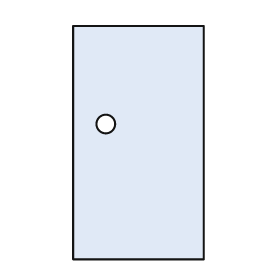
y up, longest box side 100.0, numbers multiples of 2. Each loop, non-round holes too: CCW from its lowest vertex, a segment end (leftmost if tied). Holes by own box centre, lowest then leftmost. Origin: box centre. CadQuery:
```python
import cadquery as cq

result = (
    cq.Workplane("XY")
    .moveTo(-28.0, -50.0)
    .lineTo(28.0, -50.0)
    .lineTo(28.0, 50.0)
    .lineTo(-28.0, 50.0)
    .close()
    .moveTo(-14.0, 8.0)
    .circle(4.0)
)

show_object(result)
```